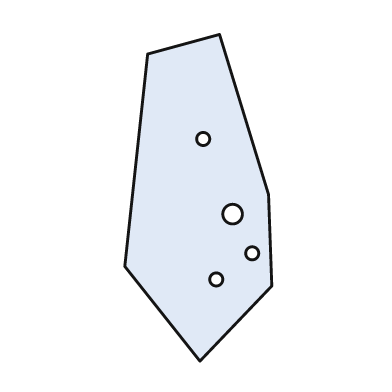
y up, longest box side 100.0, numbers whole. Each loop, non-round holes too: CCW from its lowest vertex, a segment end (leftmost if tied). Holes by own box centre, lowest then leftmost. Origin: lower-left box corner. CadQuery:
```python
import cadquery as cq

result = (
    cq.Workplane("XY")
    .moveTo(23.0, 0.0)
    .lineTo(45.0, 23.0)
    .lineTo(44.0, 51.0)
    .lineTo(29.0, 100.0)
    .lineTo(7.0, 94.0)
    .lineTo(0.0, 29.0)
    .close()
    .moveTo(28.0, 25.0)
    .circle(2.0)
    .moveTo(39.0, 33.0)
    .circle(2.0)
    .moveTo(33.0, 45.0)
    .circle(3.0)
    .moveTo(24.0, 68.0)
    .circle(2.0)
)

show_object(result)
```